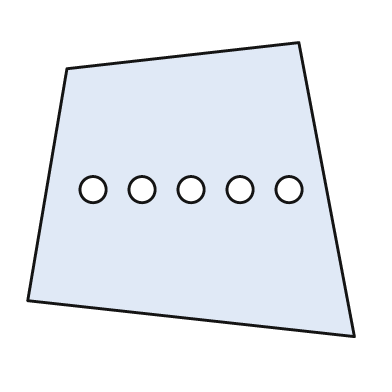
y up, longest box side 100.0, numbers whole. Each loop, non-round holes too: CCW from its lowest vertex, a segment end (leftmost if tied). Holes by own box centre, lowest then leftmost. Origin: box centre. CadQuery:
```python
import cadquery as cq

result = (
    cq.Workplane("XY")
    .moveTo(50.0, -45.0)
    .lineTo(33.0, 45.0)
    .lineTo(-38.0, 37.0)
    .lineTo(-50.0, -34.0)
    .close()
    .moveTo(-30.0, 0.0)
    .circle(4.0)
    .moveTo(-15.0, 0.0)
    .circle(4.0)
    .moveTo(0.0, 0.0)
    .circle(4.0)
    .moveTo(15.0, 0.0)
    .circle(4.0)
    .moveTo(30.0, 0.0)
    .circle(4.0)
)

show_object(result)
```